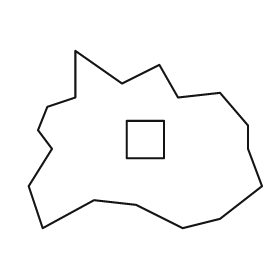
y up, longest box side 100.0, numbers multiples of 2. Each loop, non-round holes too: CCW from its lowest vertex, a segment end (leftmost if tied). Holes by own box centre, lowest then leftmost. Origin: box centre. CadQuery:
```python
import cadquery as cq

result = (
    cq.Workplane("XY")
    .moveTo(-44.0, -38.0)
    .lineTo(-22.0, -26.0)
    .lineTo(-4.0, -28.0)
    .lineTo(16.0, -38.0)
    .lineTo(32.0, -34.0)
    .lineTo(50.0, -20.0)
    .lineTo(44.0, -4.0)
    .lineTo(44.0, 6.0)
    .lineTo(32.0, 20.0)
    .lineTo(14.0, 18.0)
    .lineTo(6.0, 32.0)
    .lineTo(-10.0, 24.0)
    .lineTo(-30.0, 38.0)
    .lineTo(-30.0, 18.0)
    .lineTo(-42.0, 14.0)
    .lineTo(-46.0, 4.0)
    .lineTo(-40.0, -4.0)
    .lineTo(-50.0, -20.0)
    .close()
    .moveTo(-8.0, -8.0)
    .lineTo(8.0, -8.0)
    .lineTo(8.0, 8.0)
    .lineTo(-8.0, 8.0)
    .close()
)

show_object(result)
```